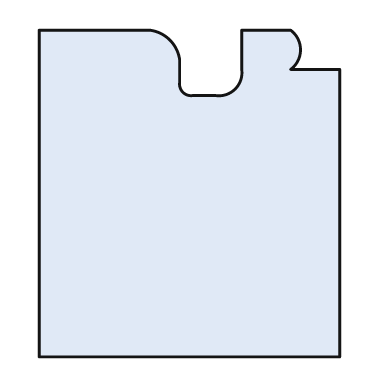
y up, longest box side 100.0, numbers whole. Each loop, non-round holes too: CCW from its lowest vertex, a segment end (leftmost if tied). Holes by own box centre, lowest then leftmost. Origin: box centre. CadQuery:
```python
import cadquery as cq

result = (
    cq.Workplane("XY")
    .moveTo(-46.0, -50.0)
    .lineTo(46.0, -50.0)
    .lineTo(46.0, 38.0)
    .lineTo(31.0, 38.0)
    .threePointArc((34.0, 44.0), (31.0, 50.0))
    .lineTo(16.0, 50.0)
    .lineTo(16.0, 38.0)
    .threePointArc((14.0, 32.0), (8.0, 30.0))
    .lineTo(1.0, 30.0)
    .threePointArc((-2.0, 31.0), (-3.0, 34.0))
    .lineTo(-3.0, 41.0)
    .threePointArc((-6.0, 47.0), (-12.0, 50.0))
    .lineTo(-46.0, 50.0)
    .close()
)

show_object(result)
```